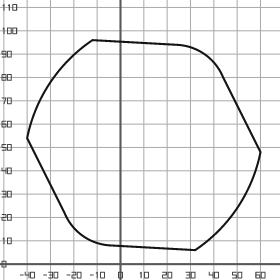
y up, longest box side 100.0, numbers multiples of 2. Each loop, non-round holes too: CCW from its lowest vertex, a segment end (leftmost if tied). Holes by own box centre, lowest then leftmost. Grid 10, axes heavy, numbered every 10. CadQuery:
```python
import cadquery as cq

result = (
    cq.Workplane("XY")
    .moveTo(32.0, 6.0)
    .threePointArc((50.0, 24.0), (60.0, 48.0))
    .lineTo(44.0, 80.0)
    .threePointArc((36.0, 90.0), (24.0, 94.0))
    .lineTo(-12.0, 96.0)
    .threePointArc((-30.0, 78.0), (-40.0, 54.0))
    .lineTo(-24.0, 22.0)
    .threePointArc((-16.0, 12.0), (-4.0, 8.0))
    .close()
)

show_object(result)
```